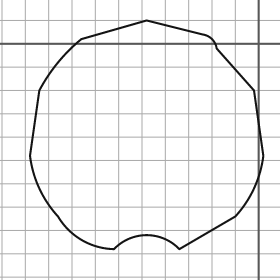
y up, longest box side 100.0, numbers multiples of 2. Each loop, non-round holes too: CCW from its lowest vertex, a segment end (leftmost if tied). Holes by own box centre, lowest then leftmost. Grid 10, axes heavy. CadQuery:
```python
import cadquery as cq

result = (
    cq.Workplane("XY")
    .moveTo(-62.0, -88.0)
    .threePointArc((-48.0, -82.0), (-34.0, -88.0))
    .lineTo(-10.0, -74.0)
    .threePointArc((-2.0, -62.0), (2.0, -48.0))
    .lineTo(-2.0, -20.0)
    .lineTo(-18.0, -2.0)
    .threePointArc((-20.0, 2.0), (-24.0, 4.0))
    .lineTo(-48.0, 10.0)
    .lineTo(-76.0, 2.0)
    .threePointArc((-86.0, -8.0), (-94.0, -20.0))
    .lineTo(-98.0, -48.0)
    .threePointArc((-94.0, -62.0), (-86.0, -74.0))
    .threePointArc((-76.0, -84.0), (-62.0, -88.0))
    .close()
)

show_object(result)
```